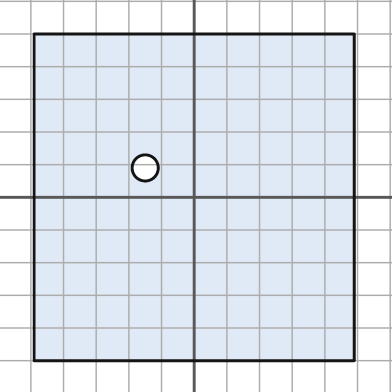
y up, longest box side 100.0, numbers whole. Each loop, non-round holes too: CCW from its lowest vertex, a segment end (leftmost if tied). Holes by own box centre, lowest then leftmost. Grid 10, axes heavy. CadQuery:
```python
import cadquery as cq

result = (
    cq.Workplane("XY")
    .moveTo(-49.0, -50.0)
    .lineTo(49.0, -50.0)
    .lineTo(49.0, 50.0)
    .lineTo(-49.0, 50.0)
    .close()
    .moveTo(-15.0, 9.0)
    .circle(4.0)
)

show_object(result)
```